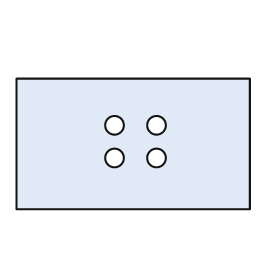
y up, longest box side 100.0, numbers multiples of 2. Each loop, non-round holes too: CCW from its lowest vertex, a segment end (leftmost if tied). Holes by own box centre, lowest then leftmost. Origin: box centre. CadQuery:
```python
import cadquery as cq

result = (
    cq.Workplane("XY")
    .moveTo(-50.0, -28.0)
    .lineTo(50.0, -28.0)
    .lineTo(50.0, 28.0)
    .lineTo(-50.0, 28.0)
    .close()
    .moveTo(-8.0, -6.0)
    .circle(4.0)
    .moveTo(10.0, -6.0)
    .circle(4.0)
    .moveTo(-8.0, 8.0)
    .circle(4.0)
    .moveTo(10.0, 8.0)
    .circle(4.0)
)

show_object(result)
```